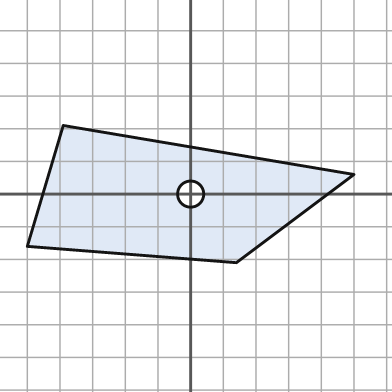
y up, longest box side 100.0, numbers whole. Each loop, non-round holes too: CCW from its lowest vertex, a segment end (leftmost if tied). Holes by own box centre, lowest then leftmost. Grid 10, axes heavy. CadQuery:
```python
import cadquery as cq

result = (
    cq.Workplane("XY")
    .moveTo(14.0, -21.0)
    .lineTo(50.0, 6.0)
    .lineTo(-39.0, 21.0)
    .lineTo(-50.0, -16.0)
    .close()
    .moveTo(0.0, 0.0)
    .circle(4.0)
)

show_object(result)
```